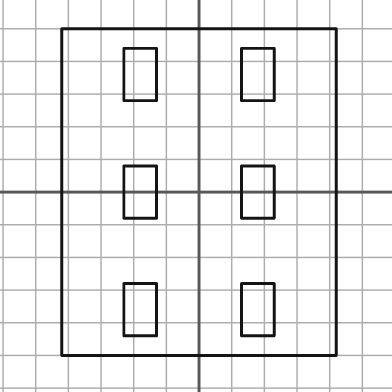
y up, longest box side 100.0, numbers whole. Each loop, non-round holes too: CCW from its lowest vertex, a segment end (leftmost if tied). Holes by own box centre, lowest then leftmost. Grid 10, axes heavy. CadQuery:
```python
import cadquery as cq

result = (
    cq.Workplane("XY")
    .moveTo(-42.0, -50.0)
    .lineTo(42.0, -50.0)
    .lineTo(42.0, 50.0)
    .lineTo(-42.0, 50.0)
    .close()
    .moveTo(-23.0, -44.0)
    .lineTo(-13.0, -44.0)
    .lineTo(-13.0, -28.0)
    .lineTo(-23.0, -28.0)
    .close()
    .moveTo(13.0, -44.0)
    .lineTo(23.0, -44.0)
    .lineTo(23.0, -28.0)
    .lineTo(13.0, -28.0)
    .close()
    .moveTo(-23.0, -8.0)
    .lineTo(-13.0, -8.0)
    .lineTo(-13.0, 8.0)
    .lineTo(-23.0, 8.0)
    .close()
    .moveTo(13.0, -8.0)
    .lineTo(23.0, -8.0)
    .lineTo(23.0, 8.0)
    .lineTo(13.0, 8.0)
    .close()
    .moveTo(-23.0, 28.0)
    .lineTo(-13.0, 28.0)
    .lineTo(-13.0, 44.0)
    .lineTo(-23.0, 44.0)
    .close()
    .moveTo(13.0, 28.0)
    .lineTo(23.0, 28.0)
    .lineTo(23.0, 44.0)
    .lineTo(13.0, 44.0)
    .close()
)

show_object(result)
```